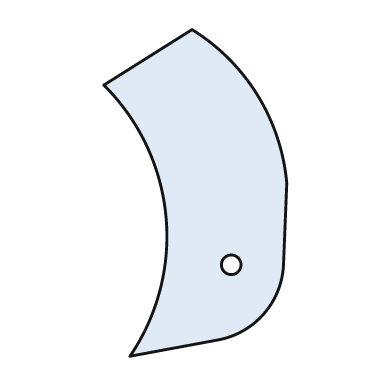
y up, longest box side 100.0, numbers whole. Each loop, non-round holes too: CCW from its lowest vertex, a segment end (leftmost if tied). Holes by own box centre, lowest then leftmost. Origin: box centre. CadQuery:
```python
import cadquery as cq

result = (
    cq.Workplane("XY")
    .moveTo(-20.0, -50.0)
    .lineTo(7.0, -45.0)
    .threePointArc((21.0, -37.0), (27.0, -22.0))
    .lineTo(28.0, 3.0)
    .threePointArc((19.0, 30.0), (-1.0, 50.0))
    .lineTo(-28.0, 33.0)
    .threePointArc((-9.0, -7.0), (-20.0, -50.0))
    .close()
    .moveTo(11.0, -22.0)
    .circle(3.0)
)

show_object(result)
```